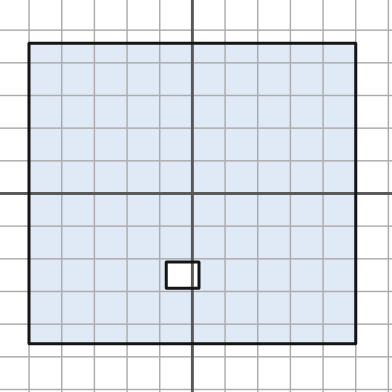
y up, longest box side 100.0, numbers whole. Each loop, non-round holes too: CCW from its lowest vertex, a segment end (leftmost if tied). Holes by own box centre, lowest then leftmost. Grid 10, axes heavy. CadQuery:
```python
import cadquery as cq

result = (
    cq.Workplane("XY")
    .moveTo(-50.0, -46.0)
    .lineTo(50.0, -46.0)
    .lineTo(50.0, 46.0)
    .lineTo(-50.0, 46.0)
    .close()
    .moveTo(-8.0, -29.0)
    .lineTo(2.0, -29.0)
    .lineTo(2.0, -21.0)
    .lineTo(-8.0, -21.0)
    .close()
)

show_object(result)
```